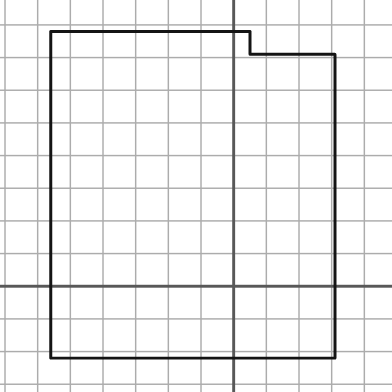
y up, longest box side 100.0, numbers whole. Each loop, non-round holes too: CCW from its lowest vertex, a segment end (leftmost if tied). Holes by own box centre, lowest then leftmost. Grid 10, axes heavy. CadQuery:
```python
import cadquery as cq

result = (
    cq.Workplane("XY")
    .moveTo(-56.0, -22.0)
    .lineTo(31.0, -22.0)
    .lineTo(31.0, 71.0)
    .lineTo(5.0, 71.0)
    .lineTo(5.0, 78.0)
    .lineTo(-56.0, 78.0)
    .close()
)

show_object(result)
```